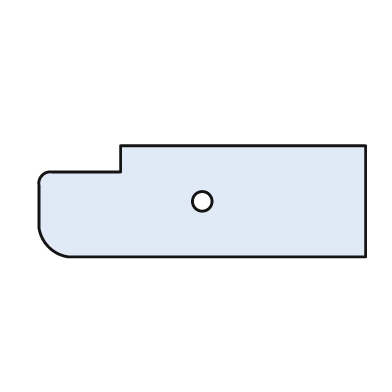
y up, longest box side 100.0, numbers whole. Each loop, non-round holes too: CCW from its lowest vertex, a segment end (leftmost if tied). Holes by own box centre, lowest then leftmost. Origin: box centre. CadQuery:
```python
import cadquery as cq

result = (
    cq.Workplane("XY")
    .moveTo(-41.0, -17.0)
    .lineTo(50.0, -17.0)
    .lineTo(50.0, 17.0)
    .lineTo(-25.0, 17.0)
    .lineTo(-25.0, 9.0)
    .lineTo(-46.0, 9.0)
    .threePointArc((-49.0, 8.0), (-50.0, 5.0))
    .lineTo(-50.0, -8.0)
    .threePointArc((-47.0, -14.0), (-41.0, -17.0))
    .close()
    .moveTo(0.0, 0.0)
    .circle(3.0)
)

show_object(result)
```